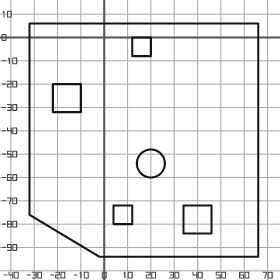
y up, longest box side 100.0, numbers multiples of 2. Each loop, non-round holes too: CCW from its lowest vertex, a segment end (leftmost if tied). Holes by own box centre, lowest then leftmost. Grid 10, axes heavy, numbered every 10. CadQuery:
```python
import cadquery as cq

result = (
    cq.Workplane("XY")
    .moveTo(-2.0, -94.0)
    .lineTo(66.0, -94.0)
    .lineTo(66.0, 6.0)
    .lineTo(-32.0, 6.0)
    .lineTo(-32.0, -76.0)
    .close()
    .moveTo(34.0, -84.0)
    .lineTo(46.0, -84.0)
    .lineTo(46.0, -72.0)
    .lineTo(34.0, -72.0)
    .close()
    .moveTo(4.0, -80.0)
    .lineTo(12.0, -80.0)
    .lineTo(12.0, -72.0)
    .lineTo(4.0, -72.0)
    .close()
    .moveTo(20.0, -54.0)
    .circle(6.0)
    .moveTo(-22.0, -32.0)
    .lineTo(-10.0, -32.0)
    .lineTo(-10.0, -20.0)
    .lineTo(-22.0, -20.0)
    .close()
    .moveTo(12.0, -8.0)
    .lineTo(20.0, -8.0)
    .lineTo(20.0, 0.0)
    .lineTo(12.0, 0.0)
    .close()
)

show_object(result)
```